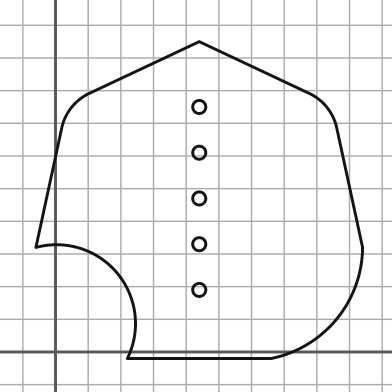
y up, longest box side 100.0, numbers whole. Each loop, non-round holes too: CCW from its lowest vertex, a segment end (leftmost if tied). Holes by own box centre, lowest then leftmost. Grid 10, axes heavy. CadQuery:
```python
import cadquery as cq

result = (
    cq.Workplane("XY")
    .moveTo(22.0, -2.0)
    .lineTo(66.0, -2.0)
    .threePointArc((86.0, 10.0), (94.0, 32.0))
    .lineTo(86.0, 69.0)
    .threePointArc((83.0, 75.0), (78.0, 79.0))
    .lineTo(44.0, 95.0)
    .lineTo(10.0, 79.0)
    .threePointArc((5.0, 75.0), (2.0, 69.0))
    .lineTo(-6.0, 32.0)
    .threePointArc((19.0, 24.0), (22.0, -2.0))
    .close()
    .moveTo(44.0, 19.0)
    .circle(2.0)
    .moveTo(44.0, 33.0)
    .circle(2.0)
    .moveTo(44.0, 47.0)
    .circle(2.0)
    .moveTo(44.0, 61.0)
    .circle(2.0)
    .moveTo(44.0, 75.0)
    .circle(2.0)
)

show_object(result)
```